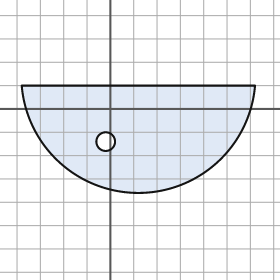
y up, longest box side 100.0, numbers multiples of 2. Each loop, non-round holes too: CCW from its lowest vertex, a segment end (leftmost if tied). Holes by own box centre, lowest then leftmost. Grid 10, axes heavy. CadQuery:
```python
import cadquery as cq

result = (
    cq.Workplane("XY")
    .moveTo(-38.0, 10.0)
    .threePointArc((12.0, -36.0), (62.0, 10.0))
    .close()
    .moveTo(-2.0, -14.0)
    .circle(4.0)
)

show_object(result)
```